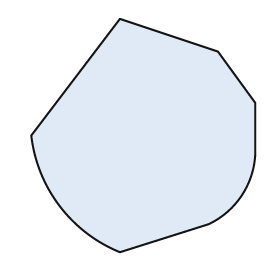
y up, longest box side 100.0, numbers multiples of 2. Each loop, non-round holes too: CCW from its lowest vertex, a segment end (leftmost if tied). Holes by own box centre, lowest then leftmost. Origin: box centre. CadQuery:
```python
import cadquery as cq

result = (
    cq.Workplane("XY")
    .moveTo(-10.0, -50.0)
    .lineTo(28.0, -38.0)
    .threePointArc((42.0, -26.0), (48.0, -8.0))
    .lineTo(48.0, 14.0)
    .lineTo(32.0, 36.0)
    .lineTo(-10.0, 50.0)
    .lineTo(-48.0, 0.0)
    .threePointArc((-36.0, -30.0), (-10.0, -50.0))
    .close()
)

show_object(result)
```